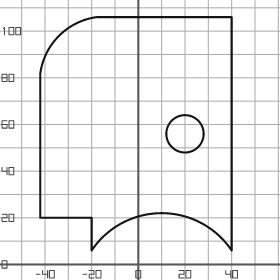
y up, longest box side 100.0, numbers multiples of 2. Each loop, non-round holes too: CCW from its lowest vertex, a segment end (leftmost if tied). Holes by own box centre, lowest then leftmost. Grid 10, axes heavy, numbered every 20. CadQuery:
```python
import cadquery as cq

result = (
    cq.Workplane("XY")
    .moveTo(-20.0, 6.0)
    .threePointArc((10.0, 22.0), (40.0, 6.0))
    .lineTo(40.0, 106.0)
    .lineTo(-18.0, 106.0)
    .threePointArc((-34.0, 98.0), (-42.0, 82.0))
    .lineTo(-42.0, 20.0)
    .lineTo(-20.0, 20.0)
    .close()
    .moveTo(20.0, 56.0)
    .circle(8.0)
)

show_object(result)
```